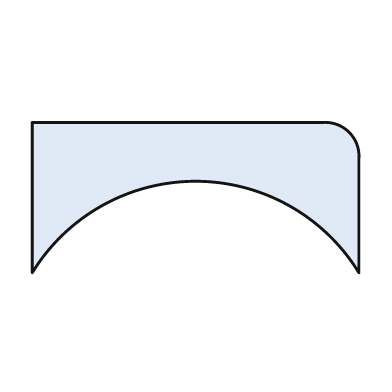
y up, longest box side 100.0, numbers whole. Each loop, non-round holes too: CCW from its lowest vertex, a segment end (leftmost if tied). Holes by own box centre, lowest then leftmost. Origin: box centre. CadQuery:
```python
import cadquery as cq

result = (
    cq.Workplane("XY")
    .moveTo(-50.0, -23.0)
    .threePointArc((0.0, 5.0), (50.0, -23.0))
    .lineTo(50.0, 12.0)
    .threePointArc((47.0, 20.0), (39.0, 23.0))
    .lineTo(-50.0, 23.0)
    .close()
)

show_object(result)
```